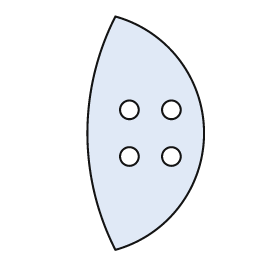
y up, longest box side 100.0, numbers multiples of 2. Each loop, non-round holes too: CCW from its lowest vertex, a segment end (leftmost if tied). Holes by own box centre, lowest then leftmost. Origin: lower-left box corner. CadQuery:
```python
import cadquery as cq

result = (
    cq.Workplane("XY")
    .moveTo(12.0, 0.0)
    .threePointArc((50.0, 50.0), (12.0, 100.0))
    .threePointArc((0.0, 50.0), (12.0, 0.0))
    .close()
    .moveTo(18.0, 40.0)
    .circle(4.0)
    .moveTo(36.0, 40.0)
    .circle(4.0)
    .moveTo(18.0, 60.0)
    .circle(4.0)
    .moveTo(36.0, 60.0)
    .circle(4.0)
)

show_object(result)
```